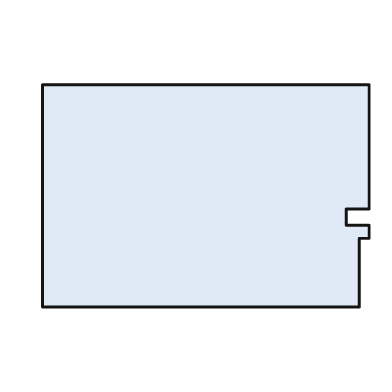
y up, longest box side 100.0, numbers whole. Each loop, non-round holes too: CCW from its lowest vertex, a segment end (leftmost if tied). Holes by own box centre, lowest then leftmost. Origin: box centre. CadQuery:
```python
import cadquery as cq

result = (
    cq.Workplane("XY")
    .moveTo(-50.0, -34.0)
    .lineTo(47.0, -34.0)
    .lineTo(47.0, -13.0)
    .lineTo(50.0, -13.0)
    .lineTo(50.0, -9.0)
    .lineTo(43.0, -9.0)
    .lineTo(43.0, -4.0)
    .lineTo(50.0, -4.0)
    .lineTo(50.0, 34.0)
    .lineTo(-50.0, 34.0)
    .close()
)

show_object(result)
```